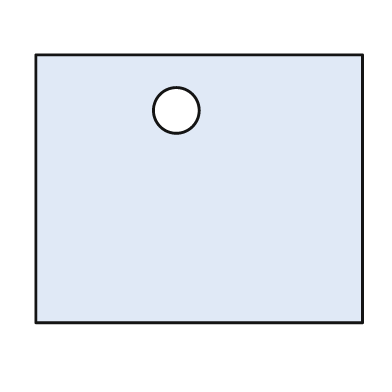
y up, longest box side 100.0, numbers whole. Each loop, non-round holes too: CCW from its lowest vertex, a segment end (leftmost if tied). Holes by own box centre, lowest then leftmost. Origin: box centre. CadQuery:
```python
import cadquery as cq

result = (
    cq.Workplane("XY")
    .moveTo(-50.0, -41.0)
    .lineTo(50.0, -41.0)
    .lineTo(50.0, 41.0)
    .lineTo(-50.0, 41.0)
    .close()
    .moveTo(-7.0, 24.0)
    .circle(7.0)
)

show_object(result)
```